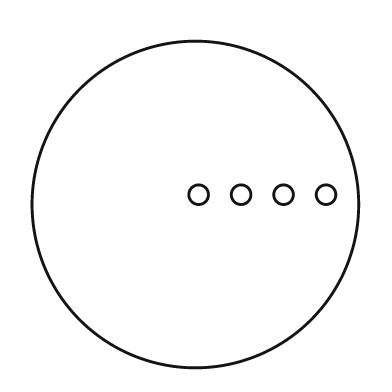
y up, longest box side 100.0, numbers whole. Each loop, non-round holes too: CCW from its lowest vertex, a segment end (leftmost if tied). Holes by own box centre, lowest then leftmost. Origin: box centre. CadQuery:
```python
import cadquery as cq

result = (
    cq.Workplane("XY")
    .moveTo(0.0, 0.0)
    .circle(50.0)
    .moveTo(1.0, 3.0)
    .circle(3.0)
    .moveTo(14.0, 3.0)
    .circle(3.0)
    .moveTo(27.0, 3.0)
    .circle(3.0)
    .moveTo(40.0, 3.0)
    .circle(3.0)
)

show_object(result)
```